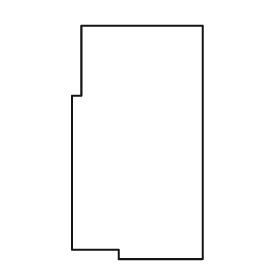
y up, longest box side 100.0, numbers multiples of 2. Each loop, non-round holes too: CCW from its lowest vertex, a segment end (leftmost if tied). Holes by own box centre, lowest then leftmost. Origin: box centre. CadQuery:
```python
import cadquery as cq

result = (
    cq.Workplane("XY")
    .moveTo(-8.0, -50.0)
    .lineTo(28.0, -50.0)
    .lineTo(28.0, 50.0)
    .lineTo(-24.0, 50.0)
    .lineTo(-24.0, 20.0)
    .lineTo(-28.0, 20.0)
    .lineTo(-28.0, -46.0)
    .lineTo(-8.0, -46.0)
    .close()
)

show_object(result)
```